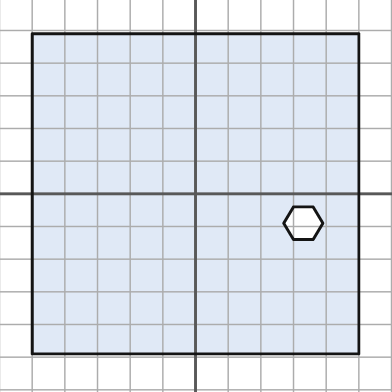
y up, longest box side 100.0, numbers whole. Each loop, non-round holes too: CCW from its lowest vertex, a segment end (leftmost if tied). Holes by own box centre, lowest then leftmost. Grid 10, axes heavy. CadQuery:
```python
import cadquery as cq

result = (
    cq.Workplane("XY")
    .moveTo(-50.0, -49.0)
    .lineTo(50.0, -49.0)
    .lineTo(50.0, 49.0)
    .lineTo(-50.0, 49.0)
    .close()
    .moveTo(30.0, -14.0)
    .lineTo(36.0, -14.0)
    .lineTo(39.0, -9.0)
    .lineTo(36.0, -4.0)
    .lineTo(30.0, -4.0)
    .lineTo(27.0, -9.0)
    .close()
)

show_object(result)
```